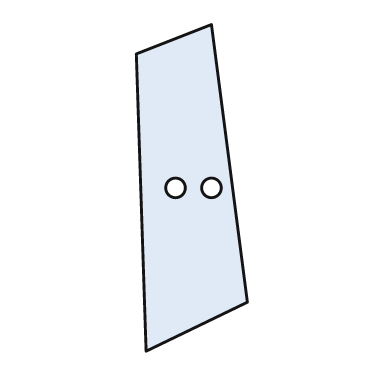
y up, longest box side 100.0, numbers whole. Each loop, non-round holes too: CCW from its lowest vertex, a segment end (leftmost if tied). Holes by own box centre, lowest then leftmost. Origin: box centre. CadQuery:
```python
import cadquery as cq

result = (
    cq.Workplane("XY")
    .moveTo(-14.0, -50.0)
    .lineTo(17.0, -35.0)
    .lineTo(6.0, 50.0)
    .lineTo(-17.0, 41.0)
    .close()
    .moveTo(-5.0, 0.0)
    .circle(3.0)
    .moveTo(6.0, 0.0)
    .circle(3.0)
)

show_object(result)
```